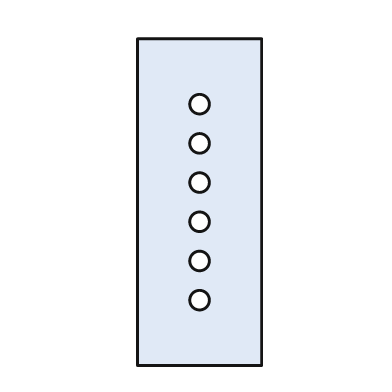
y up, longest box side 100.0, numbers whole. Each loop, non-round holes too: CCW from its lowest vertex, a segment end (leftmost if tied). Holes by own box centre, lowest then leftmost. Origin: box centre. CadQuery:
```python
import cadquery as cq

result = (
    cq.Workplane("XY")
    .moveTo(-19.0, -50.0)
    .lineTo(19.0, -50.0)
    .lineTo(19.0, 50.0)
    .lineTo(-19.0, 50.0)
    .close()
    .moveTo(0.0, -30.0)
    .circle(3.0)
    .moveTo(0.0, -18.0)
    .circle(3.0)
    .moveTo(0.0, -6.0)
    .circle(3.0)
    .moveTo(0.0, 6.0)
    .circle(3.0)
    .moveTo(0.0, 18.0)
    .circle(3.0)
    .moveTo(0.0, 30.0)
    .circle(3.0)
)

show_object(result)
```